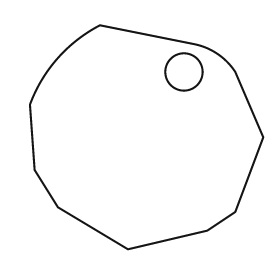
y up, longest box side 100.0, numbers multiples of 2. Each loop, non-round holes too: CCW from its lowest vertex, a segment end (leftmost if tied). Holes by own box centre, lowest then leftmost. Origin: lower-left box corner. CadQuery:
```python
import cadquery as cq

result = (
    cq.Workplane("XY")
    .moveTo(42.0, 0.0)
    .lineTo(76.0, 8.0)
    .lineTo(88.0, 16.0)
    .lineTo(100.0, 48.0)
    .lineTo(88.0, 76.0)
    .threePointArc((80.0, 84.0), (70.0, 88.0))
    .lineTo(30.0, 96.0)
    .threePointArc((12.0, 82.0), (0.0, 62.0))
    .lineTo(2.0, 34.0)
    .lineTo(12.0, 18.0)
    .close()
    .moveTo(66.0, 76.0)
    .circle(8.0)
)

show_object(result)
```